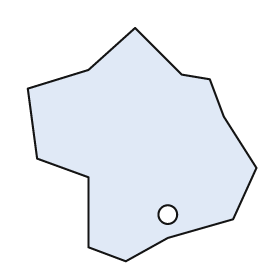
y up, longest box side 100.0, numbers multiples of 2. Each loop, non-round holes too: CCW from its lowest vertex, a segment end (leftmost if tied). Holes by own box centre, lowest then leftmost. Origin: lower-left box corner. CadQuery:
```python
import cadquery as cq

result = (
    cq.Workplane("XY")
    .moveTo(42.0, 0.0)
    .lineTo(60.0, 10.0)
    .lineTo(88.0, 18.0)
    .lineTo(98.0, 40.0)
    .lineTo(84.0, 62.0)
    .lineTo(78.0, 78.0)
    .lineTo(66.0, 80.0)
    .lineTo(46.0, 100.0)
    .lineTo(26.0, 82.0)
    .lineTo(0.0, 74.0)
    .lineTo(4.0, 44.0)
    .lineTo(26.0, 36.0)
    .lineTo(26.0, 6.0)
    .close()
    .moveTo(60.0, 20.0)
    .circle(4.0)
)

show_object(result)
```